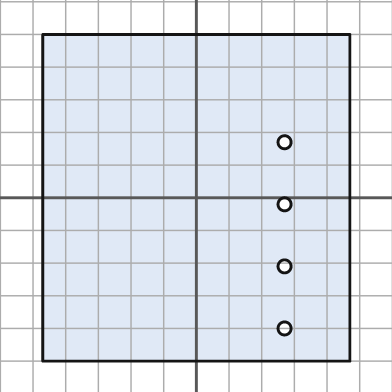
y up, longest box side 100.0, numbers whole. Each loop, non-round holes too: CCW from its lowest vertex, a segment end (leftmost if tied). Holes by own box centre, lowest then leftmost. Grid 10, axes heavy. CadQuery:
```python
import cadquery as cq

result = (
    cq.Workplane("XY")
    .moveTo(-47.0, -50.0)
    .lineTo(47.0, -50.0)
    .lineTo(47.0, 50.0)
    .lineTo(-47.0, 50.0)
    .close()
    .moveTo(27.0, -40.0)
    .circle(2.0)
    .moveTo(27.0, -21.0)
    .circle(2.0)
    .moveTo(27.0, -2.0)
    .circle(2.0)
    .moveTo(27.0, 17.0)
    .circle(2.0)
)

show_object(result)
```